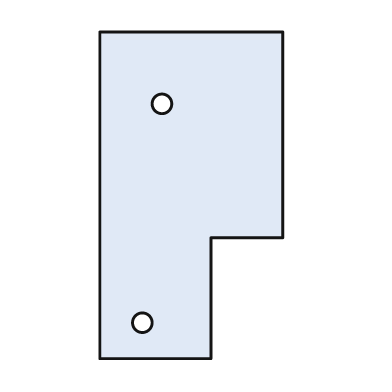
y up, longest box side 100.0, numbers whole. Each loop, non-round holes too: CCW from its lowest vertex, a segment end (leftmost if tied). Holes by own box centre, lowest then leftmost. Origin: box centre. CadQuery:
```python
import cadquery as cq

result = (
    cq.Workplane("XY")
    .moveTo(-28.0, -50.0)
    .lineTo(6.0, -50.0)
    .lineTo(6.0, -13.0)
    .lineTo(28.0, -13.0)
    .lineTo(28.0, 50.0)
    .lineTo(-28.0, 50.0)
    .close()
    .moveTo(-15.0, -39.0)
    .circle(3.0)
    .moveTo(-9.0, 28.0)
    .circle(3.0)
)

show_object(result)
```